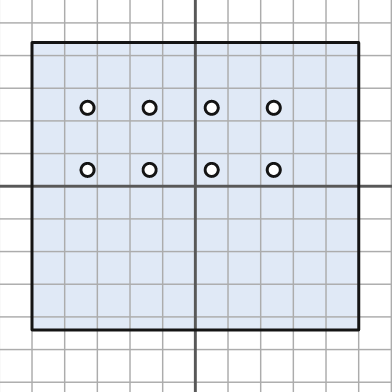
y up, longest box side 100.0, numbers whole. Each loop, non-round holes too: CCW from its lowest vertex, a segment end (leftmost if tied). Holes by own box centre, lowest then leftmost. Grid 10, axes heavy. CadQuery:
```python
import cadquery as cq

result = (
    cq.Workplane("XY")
    .moveTo(-50.0, -44.0)
    .lineTo(50.0, -44.0)
    .lineTo(50.0, 44.0)
    .lineTo(-50.0, 44.0)
    .close()
    .moveTo(-33.0, 5.0)
    .circle(2.0)
    .moveTo(-14.0, 5.0)
    .circle(2.0)
    .moveTo(5.0, 5.0)
    .circle(2.0)
    .moveTo(24.0, 5.0)
    .circle(2.0)
    .moveTo(-33.0, 24.0)
    .circle(2.0)
    .moveTo(-14.0, 24.0)
    .circle(2.0)
    .moveTo(5.0, 24.0)
    .circle(2.0)
    .moveTo(24.0, 24.0)
    .circle(2.0)
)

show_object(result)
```